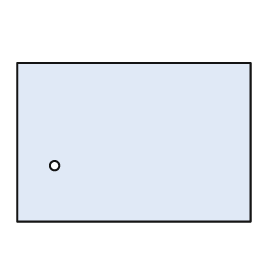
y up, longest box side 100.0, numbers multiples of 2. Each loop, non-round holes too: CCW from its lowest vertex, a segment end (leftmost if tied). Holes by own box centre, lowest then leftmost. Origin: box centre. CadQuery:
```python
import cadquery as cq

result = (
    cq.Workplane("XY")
    .moveTo(-50.0, -34.0)
    .lineTo(50.0, -34.0)
    .lineTo(50.0, 34.0)
    .lineTo(-50.0, 34.0)
    .close()
    .moveTo(-34.0, -10.0)
    .circle(2.0)
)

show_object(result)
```